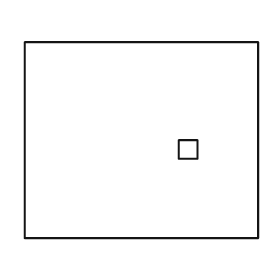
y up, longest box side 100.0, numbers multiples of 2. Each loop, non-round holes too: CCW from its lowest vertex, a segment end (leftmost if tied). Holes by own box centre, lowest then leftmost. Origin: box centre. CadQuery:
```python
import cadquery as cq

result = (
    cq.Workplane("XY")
    .moveTo(-50.0, -42.0)
    .lineTo(50.0, -42.0)
    .lineTo(50.0, 42.0)
    .lineTo(-50.0, 42.0)
    .close()
    .moveTo(16.0, -8.0)
    .lineTo(24.0, -8.0)
    .lineTo(24.0, 0.0)
    .lineTo(16.0, 0.0)
    .close()
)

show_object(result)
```